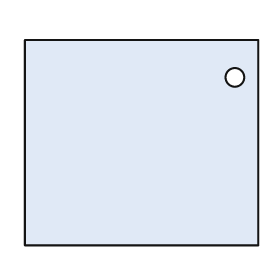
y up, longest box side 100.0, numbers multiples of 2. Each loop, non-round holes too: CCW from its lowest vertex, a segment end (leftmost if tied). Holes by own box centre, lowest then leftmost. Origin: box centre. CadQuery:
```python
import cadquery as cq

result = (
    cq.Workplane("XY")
    .moveTo(-50.0, -44.0)
    .lineTo(50.0, -44.0)
    .lineTo(50.0, 44.0)
    .lineTo(-50.0, 44.0)
    .close()
    .moveTo(40.0, 28.0)
    .circle(4.0)
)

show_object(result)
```